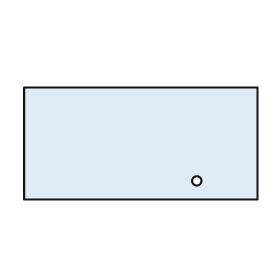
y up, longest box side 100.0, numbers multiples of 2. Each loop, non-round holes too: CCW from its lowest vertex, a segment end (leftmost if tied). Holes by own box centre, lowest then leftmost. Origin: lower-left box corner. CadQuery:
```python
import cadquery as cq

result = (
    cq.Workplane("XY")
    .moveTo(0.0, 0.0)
    .lineTo(100.0, 0.0)
    .lineTo(100.0, 48.0)
    .lineTo(0.0, 48.0)
    .close()
    .moveTo(74.0, 8.0)
    .circle(2.0)
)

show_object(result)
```